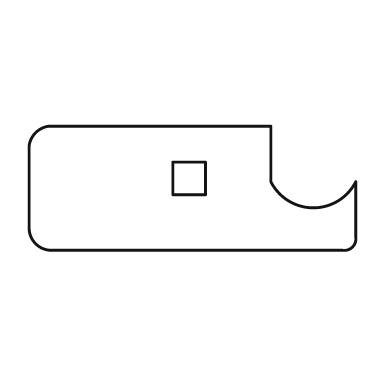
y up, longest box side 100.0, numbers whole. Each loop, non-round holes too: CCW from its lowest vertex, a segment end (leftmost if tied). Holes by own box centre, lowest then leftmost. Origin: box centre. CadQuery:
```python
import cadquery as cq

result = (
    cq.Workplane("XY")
    .moveTo(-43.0, -19.0)
    .lineTo(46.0, -19.0)
    .threePointArc((49.0, -18.0), (50.0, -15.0))
    .lineTo(50.0, 2.0)
    .threePointArc((37.0, -6.0), (24.0, 2.0))
    .lineTo(24.0, 19.0)
    .lineTo(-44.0, 19.0)
    .threePointArc((-48.0, 17.0), (-50.0, 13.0))
    .lineTo(-50.0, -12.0)
    .threePointArc((-48.0, -17.0), (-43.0, -19.0))
    .close()
    .moveTo(-6.0, -2.0)
    .lineTo(4.0, -2.0)
    .lineTo(4.0, 8.0)
    .lineTo(-6.0, 8.0)
    .close()
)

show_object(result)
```